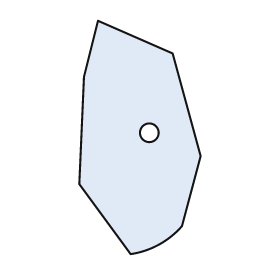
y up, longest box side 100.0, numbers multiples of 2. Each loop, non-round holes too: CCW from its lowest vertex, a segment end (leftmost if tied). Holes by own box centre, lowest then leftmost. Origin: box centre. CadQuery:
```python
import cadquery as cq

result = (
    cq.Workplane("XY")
    .moveTo(-4.0, -50.0)
    .threePointArc((8.0, -46.0), (18.0, -38.0))
    .lineTo(26.0, -8.0)
    .lineTo(14.0, 36.0)
    .lineTo(-18.0, 50.0)
    .lineTo(-24.0, 26.0)
    .lineTo(-26.0, -20.0)
    .close()
    .moveTo(4.0, 2.0)
    .circle(4.0)
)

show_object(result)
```